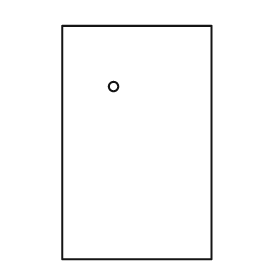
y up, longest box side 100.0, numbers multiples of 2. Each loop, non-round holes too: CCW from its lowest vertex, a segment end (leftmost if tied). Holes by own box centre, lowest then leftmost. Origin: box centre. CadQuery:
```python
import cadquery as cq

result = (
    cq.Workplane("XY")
    .moveTo(-32.0, -50.0)
    .lineTo(32.0, -50.0)
    .lineTo(32.0, 50.0)
    .lineTo(-32.0, 50.0)
    .close()
    .moveTo(-10.0, 24.0)
    .circle(2.0)
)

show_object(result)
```